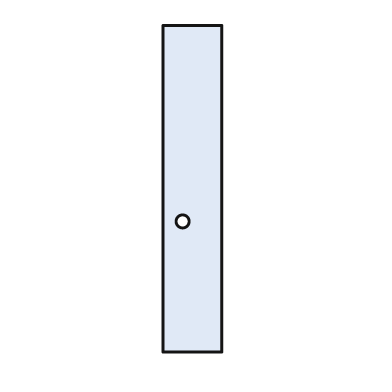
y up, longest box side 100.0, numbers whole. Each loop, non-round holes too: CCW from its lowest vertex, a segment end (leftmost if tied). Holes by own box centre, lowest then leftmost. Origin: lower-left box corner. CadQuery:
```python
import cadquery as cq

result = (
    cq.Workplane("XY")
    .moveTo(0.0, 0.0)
    .lineTo(18.0, 0.0)
    .lineTo(18.0, 100.0)
    .lineTo(0.0, 100.0)
    .close()
    .moveTo(6.0, 40.0)
    .circle(2.0)
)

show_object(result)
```